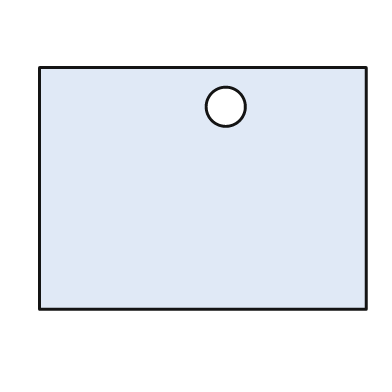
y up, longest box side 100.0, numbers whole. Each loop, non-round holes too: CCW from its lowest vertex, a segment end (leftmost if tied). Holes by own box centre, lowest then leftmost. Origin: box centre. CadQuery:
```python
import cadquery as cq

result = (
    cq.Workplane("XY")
    .moveTo(-50.0, -37.0)
    .lineTo(50.0, -37.0)
    .lineTo(50.0, 37.0)
    .lineTo(-50.0, 37.0)
    .close()
    .moveTo(7.0, 25.0)
    .circle(6.0)
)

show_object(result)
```